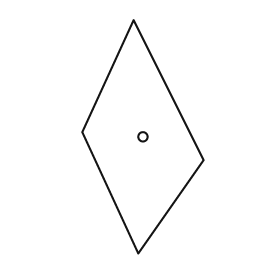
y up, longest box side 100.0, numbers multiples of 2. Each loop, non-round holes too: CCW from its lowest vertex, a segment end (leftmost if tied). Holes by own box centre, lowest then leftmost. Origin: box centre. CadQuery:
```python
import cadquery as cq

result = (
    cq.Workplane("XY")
    .moveTo(-2.0, -50.0)
    .lineTo(26.0, -10.0)
    .lineTo(-4.0, 50.0)
    .lineTo(-26.0, 2.0)
    .close()
    .moveTo(0.0, 0.0)
    .circle(2.0)
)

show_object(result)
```